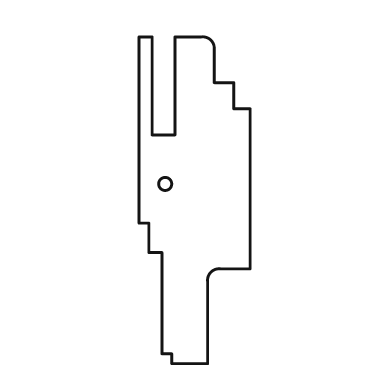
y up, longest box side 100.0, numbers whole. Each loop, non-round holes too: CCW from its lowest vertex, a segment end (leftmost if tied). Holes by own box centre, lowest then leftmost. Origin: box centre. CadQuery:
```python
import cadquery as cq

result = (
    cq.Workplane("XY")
    .moveTo(-7.0, -50.0)
    .lineTo(4.0, -50.0)
    .lineTo(4.0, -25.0)
    .threePointArc((5.0, -22.0), (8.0, -21.0))
    .lineTo(17.0, -21.0)
    .lineTo(17.0, 28.0)
    .lineTo(12.0, 28.0)
    .lineTo(12.0, 36.0)
    .lineTo(6.0, 36.0)
    .lineTo(6.0, 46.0)
    .threePointArc((5.0, 49.0), (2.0, 50.0))
    .lineTo(-6.0, 50.0)
    .lineTo(-6.0, 20.0)
    .lineTo(-13.0, 20.0)
    .lineTo(-13.0, 50.0)
    .lineTo(-17.0, 50.0)
    .lineTo(-17.0, -7.0)
    .lineTo(-14.0, -7.0)
    .lineTo(-14.0, -16.0)
    .lineTo(-10.0, -16.0)
    .lineTo(-10.0, -47.0)
    .lineTo(-7.0, -47.0)
    .close()
    .moveTo(-9.0, 5.0)
    .circle(2.0)
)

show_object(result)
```